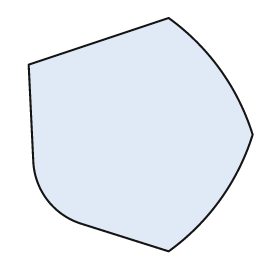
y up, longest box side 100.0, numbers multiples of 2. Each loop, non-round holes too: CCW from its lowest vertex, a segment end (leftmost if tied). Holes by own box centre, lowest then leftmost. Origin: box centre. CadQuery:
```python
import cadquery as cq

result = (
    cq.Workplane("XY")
    .moveTo(12.0, -50.0)
    .threePointArc((34.0, -28.0), (48.0, 0.0))
    .threePointArc((34.0, 28.0), (12.0, 50.0))
    .lineTo(-48.0, 30.0)
    .lineTo(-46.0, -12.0)
    .threePointArc((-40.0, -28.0), (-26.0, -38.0))
    .close()
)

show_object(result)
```